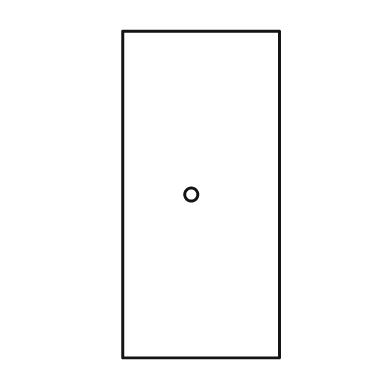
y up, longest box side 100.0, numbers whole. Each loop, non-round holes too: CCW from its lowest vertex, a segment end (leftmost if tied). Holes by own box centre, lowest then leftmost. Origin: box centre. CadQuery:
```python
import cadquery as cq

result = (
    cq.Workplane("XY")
    .moveTo(-24.0, -50.0)
    .lineTo(24.0, -50.0)
    .lineTo(24.0, 50.0)
    .lineTo(-24.0, 50.0)
    .close()
    .moveTo(-3.0, 0.0)
    .circle(2.0)
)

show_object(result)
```